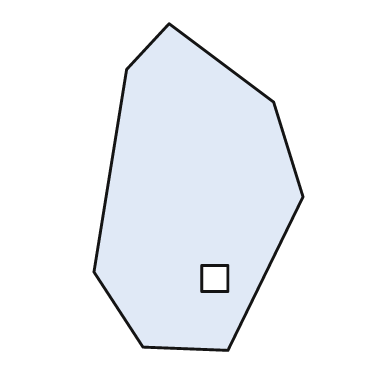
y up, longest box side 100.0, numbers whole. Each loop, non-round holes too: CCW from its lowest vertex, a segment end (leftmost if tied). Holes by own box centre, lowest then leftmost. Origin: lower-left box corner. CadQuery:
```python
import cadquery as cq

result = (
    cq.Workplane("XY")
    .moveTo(41.0, 0.0)
    .lineTo(64.0, 47.0)
    .lineTo(55.0, 76.0)
    .lineTo(23.0, 100.0)
    .lineTo(10.0, 86.0)
    .lineTo(0.0, 24.0)
    .lineTo(15.0, 1.0)
    .close()
    .moveTo(33.0, 18.0)
    .lineTo(41.0, 18.0)
    .lineTo(41.0, 26.0)
    .lineTo(33.0, 26.0)
    .close()
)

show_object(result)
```